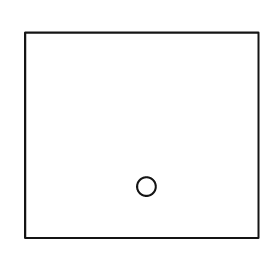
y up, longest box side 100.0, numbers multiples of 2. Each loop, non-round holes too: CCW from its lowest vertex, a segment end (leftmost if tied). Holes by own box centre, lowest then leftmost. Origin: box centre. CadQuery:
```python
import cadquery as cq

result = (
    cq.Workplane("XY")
    .moveTo(-50.0, -44.0)
    .lineTo(50.0, -44.0)
    .lineTo(50.0, 44.0)
    .lineTo(-50.0, 44.0)
    .close()
    .moveTo(2.0, -22.0)
    .circle(4.0)
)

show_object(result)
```